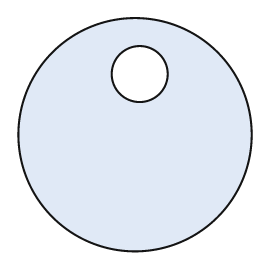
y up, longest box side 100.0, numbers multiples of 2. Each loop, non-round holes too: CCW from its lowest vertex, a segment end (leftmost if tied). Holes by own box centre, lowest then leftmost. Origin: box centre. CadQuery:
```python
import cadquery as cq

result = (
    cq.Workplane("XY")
    .moveTo(0.0, 0.0)
    .circle(50.0)
    .moveTo(2.0, 26.0)
    .circle(12.0)
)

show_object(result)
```